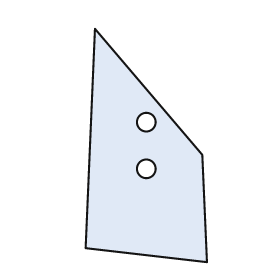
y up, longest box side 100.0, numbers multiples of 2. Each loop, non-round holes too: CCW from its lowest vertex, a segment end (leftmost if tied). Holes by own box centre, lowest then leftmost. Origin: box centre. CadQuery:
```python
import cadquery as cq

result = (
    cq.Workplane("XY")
    .moveTo(26.0, -50.0)
    .lineTo(24.0, -4.0)
    .lineTo(-22.0, 50.0)
    .lineTo(-26.0, -44.0)
    .close()
    .moveTo(0.0, -10.0)
    .circle(4.0)
    .moveTo(0.0, 10.0)
    .circle(4.0)
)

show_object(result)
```